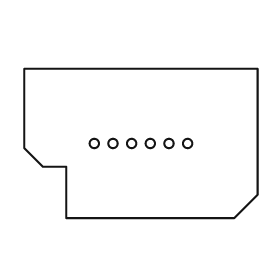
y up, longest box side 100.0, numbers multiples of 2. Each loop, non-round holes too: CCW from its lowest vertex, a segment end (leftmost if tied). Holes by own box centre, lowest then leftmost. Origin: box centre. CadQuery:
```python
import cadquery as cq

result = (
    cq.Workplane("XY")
    .moveTo(-32.0, -32.0)
    .lineTo(40.0, -32.0)
    .lineTo(50.0, -22.0)
    .lineTo(50.0, 32.0)
    .lineTo(-50.0, 32.0)
    .lineTo(-50.0, -2.0)
    .lineTo(-42.0, -10.0)
    .lineTo(-32.0, -10.0)
    .close()
    .moveTo(-20.0, 0.0)
    .circle(2.0)
    .moveTo(-12.0, 0.0)
    .circle(2.0)
    .moveTo(-4.0, 0.0)
    .circle(2.0)
    .moveTo(4.0, 0.0)
    .circle(2.0)
    .moveTo(12.0, 0.0)
    .circle(2.0)
    .moveTo(20.0, 0.0)
    .circle(2.0)
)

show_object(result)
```